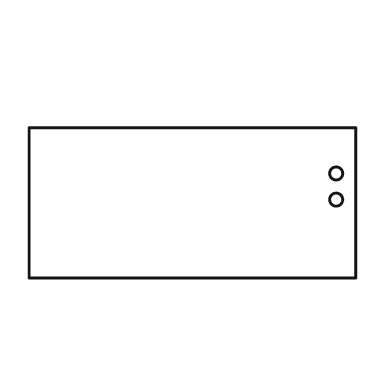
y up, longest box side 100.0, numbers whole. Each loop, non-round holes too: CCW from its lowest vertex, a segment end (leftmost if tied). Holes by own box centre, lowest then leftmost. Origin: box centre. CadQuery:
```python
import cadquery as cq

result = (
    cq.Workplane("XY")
    .moveTo(-50.0, -23.0)
    .lineTo(50.0, -23.0)
    .lineTo(50.0, 23.0)
    .lineTo(-50.0, 23.0)
    .close()
    .moveTo(44.0, 1.0)
    .circle(2.0)
    .moveTo(44.0, 9.0)
    .circle(2.0)
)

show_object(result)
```